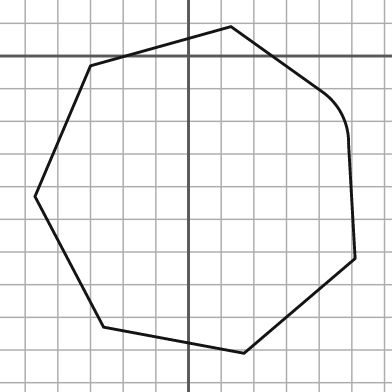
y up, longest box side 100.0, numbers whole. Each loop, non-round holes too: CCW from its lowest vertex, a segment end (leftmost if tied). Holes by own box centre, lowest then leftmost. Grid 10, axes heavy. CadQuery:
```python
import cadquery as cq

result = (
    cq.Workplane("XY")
    .moveTo(17.0, -91.0)
    .lineTo(51.0, -62.0)
    .lineTo(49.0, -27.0)
    .threePointArc((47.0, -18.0), (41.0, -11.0))
    .lineTo(13.0, 9.0)
    .lineTo(-30.0, -3.0)
    .lineTo(-47.0, -43.0)
    .lineTo(-26.0, -83.0)
    .close()
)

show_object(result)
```